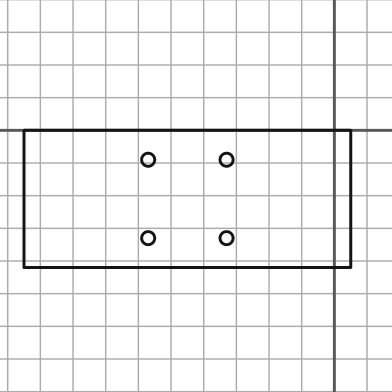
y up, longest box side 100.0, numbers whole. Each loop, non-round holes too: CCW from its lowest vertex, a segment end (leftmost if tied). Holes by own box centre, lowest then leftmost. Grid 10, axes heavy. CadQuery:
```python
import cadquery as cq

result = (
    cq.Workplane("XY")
    .moveTo(-95.0, -42.0)
    .lineTo(5.0, -42.0)
    .lineTo(5.0, 0.0)
    .lineTo(-95.0, 0.0)
    .close()
    .moveTo(-57.0, -33.0)
    .circle(2.0)
    .moveTo(-33.0, -33.0)
    .circle(2.0)
    .moveTo(-57.0, -9.0)
    .circle(2.0)
    .moveTo(-33.0, -9.0)
    .circle(2.0)
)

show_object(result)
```